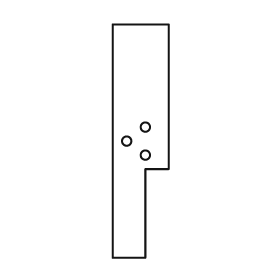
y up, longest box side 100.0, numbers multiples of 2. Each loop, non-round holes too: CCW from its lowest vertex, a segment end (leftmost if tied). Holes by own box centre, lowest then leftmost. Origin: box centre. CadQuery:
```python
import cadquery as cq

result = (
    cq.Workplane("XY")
    .moveTo(-12.0, -50.0)
    .lineTo(2.0, -50.0)
    .lineTo(2.0, -12.0)
    .lineTo(12.0, -12.0)
    .lineTo(12.0, 50.0)
    .lineTo(-12.0, 50.0)
    .close()
    .moveTo(2.0, -6.0)
    .circle(2.0)
    .moveTo(-6.0, 0.0)
    .circle(2.0)
    .moveTo(2.0, 6.0)
    .circle(2.0)
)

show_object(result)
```